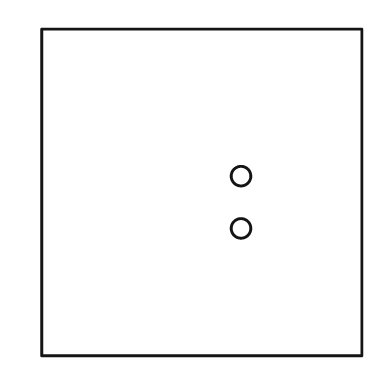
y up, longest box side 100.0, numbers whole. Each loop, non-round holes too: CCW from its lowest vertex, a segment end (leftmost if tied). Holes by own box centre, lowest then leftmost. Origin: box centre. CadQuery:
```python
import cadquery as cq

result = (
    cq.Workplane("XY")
    .moveTo(-49.0, -50.0)
    .lineTo(49.0, -50.0)
    .lineTo(49.0, 50.0)
    .lineTo(-49.0, 50.0)
    .close()
    .moveTo(12.0, -11.0)
    .circle(3.0)
    .moveTo(12.0, 5.0)
    .circle(3.0)
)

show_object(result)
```